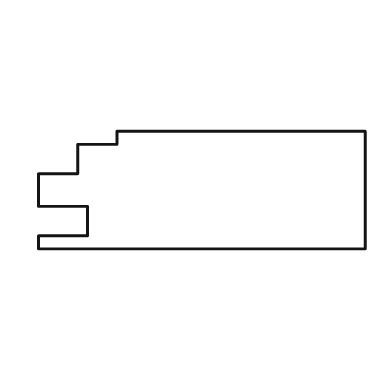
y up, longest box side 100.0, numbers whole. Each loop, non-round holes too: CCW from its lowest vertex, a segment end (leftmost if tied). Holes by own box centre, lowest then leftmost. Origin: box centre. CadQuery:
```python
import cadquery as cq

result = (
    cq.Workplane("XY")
    .moveTo(-50.0, -18.0)
    .lineTo(50.0, -18.0)
    .lineTo(50.0, 18.0)
    .lineTo(-26.0, 18.0)
    .lineTo(-26.0, 14.0)
    .lineTo(-38.0, 14.0)
    .lineTo(-38.0, 5.0)
    .lineTo(-50.0, 5.0)
    .lineTo(-50.0, -5.0)
    .lineTo(-35.0, -5.0)
    .lineTo(-35.0, -14.0)
    .lineTo(-50.0, -14.0)
    .close()
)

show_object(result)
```